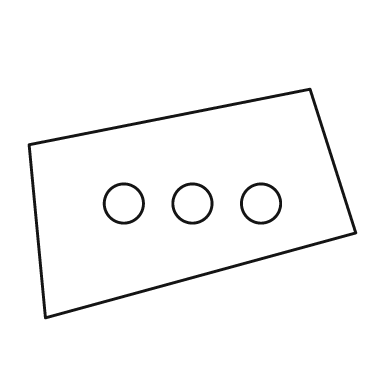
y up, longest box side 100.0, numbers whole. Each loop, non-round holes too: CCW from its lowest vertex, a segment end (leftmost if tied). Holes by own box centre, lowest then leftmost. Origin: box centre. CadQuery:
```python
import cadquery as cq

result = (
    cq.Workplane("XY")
    .moveTo(-45.0, -35.0)
    .lineTo(50.0, -9.0)
    .lineTo(36.0, 35.0)
    .lineTo(-50.0, 18.0)
    .close()
    .moveTo(-21.0, 0.0)
    .circle(6.0)
    .moveTo(0.0, 0.0)
    .circle(6.0)
    .moveTo(21.0, 0.0)
    .circle(6.0)
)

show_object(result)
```